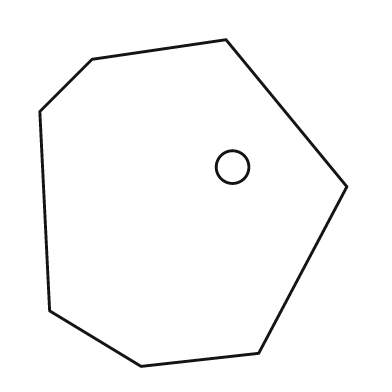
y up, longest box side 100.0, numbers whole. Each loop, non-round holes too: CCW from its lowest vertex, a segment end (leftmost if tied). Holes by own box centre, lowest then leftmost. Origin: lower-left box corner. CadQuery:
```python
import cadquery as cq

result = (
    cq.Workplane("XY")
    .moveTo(31.0, 0.0)
    .lineTo(67.0, 4.0)
    .lineTo(94.0, 55.0)
    .lineTo(57.0, 100.0)
    .lineTo(16.0, 94.0)
    .lineTo(0.0, 78.0)
    .lineTo(3.0, 17.0)
    .close()
    .moveTo(59.0, 61.0)
    .circle(5.0)
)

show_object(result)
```